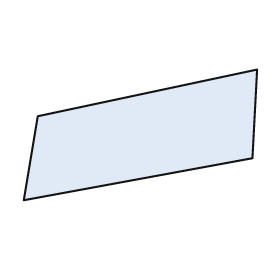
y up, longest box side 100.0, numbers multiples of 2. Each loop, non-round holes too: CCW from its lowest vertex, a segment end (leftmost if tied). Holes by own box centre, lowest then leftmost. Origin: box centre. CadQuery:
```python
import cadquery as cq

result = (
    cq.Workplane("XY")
    .moveTo(-50.0, -28.0)
    .lineTo(48.0, -10.0)
    .lineTo(50.0, 28.0)
    .lineTo(-44.0, 8.0)
    .close()
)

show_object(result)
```